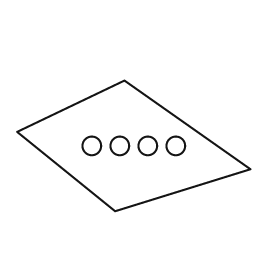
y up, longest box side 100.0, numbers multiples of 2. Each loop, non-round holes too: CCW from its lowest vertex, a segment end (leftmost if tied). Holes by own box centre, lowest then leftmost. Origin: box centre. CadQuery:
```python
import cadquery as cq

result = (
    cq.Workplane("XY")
    .moveTo(-8.0, -28.0)
    .lineTo(50.0, -10.0)
    .lineTo(-4.0, 28.0)
    .lineTo(-50.0, 6.0)
    .close()
    .moveTo(-18.0, 0.0)
    .circle(4.0)
    .moveTo(-6.0, 0.0)
    .circle(4.0)
    .moveTo(6.0, 0.0)
    .circle(4.0)
    .moveTo(18.0, 0.0)
    .circle(4.0)
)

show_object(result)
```